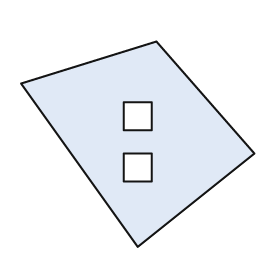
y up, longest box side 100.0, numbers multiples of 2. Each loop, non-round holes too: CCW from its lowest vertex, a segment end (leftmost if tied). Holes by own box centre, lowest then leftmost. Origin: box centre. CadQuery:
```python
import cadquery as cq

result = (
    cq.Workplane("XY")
    .moveTo(0.0, -44.0)
    .lineTo(50.0, -4.0)
    .lineTo(8.0, 44.0)
    .lineTo(-50.0, 26.0)
    .close()
    .moveTo(-6.0, -16.0)
    .lineTo(6.0, -16.0)
    .lineTo(6.0, -4.0)
    .lineTo(-6.0, -4.0)
    .close()
    .moveTo(-6.0, 6.0)
    .lineTo(6.0, 6.0)
    .lineTo(6.0, 18.0)
    .lineTo(-6.0, 18.0)
    .close()
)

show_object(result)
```